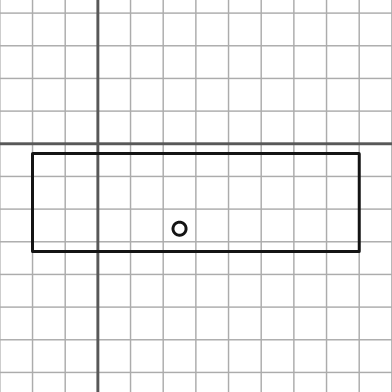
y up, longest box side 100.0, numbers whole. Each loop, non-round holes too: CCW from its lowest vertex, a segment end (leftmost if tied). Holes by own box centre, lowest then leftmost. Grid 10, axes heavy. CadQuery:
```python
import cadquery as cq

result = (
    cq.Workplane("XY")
    .moveTo(-20.0, -33.0)
    .lineTo(80.0, -33.0)
    .lineTo(80.0, -3.0)
    .lineTo(-20.0, -3.0)
    .close()
    .moveTo(25.0, -26.0)
    .circle(2.0)
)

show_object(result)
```